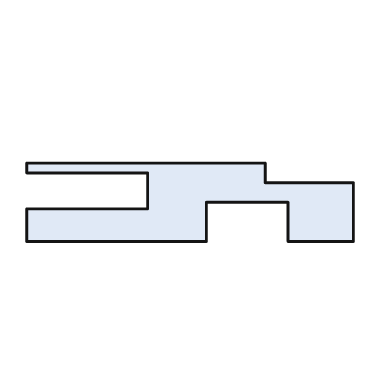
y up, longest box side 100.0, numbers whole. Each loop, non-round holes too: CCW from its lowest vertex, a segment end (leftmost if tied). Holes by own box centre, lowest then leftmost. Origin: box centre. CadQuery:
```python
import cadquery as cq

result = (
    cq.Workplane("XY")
    .moveTo(-50.0, -12.0)
    .lineTo(5.0, -12.0)
    .lineTo(5.0, 0.0)
    .lineTo(30.0, 0.0)
    .lineTo(30.0, -12.0)
    .lineTo(50.0, -12.0)
    .lineTo(50.0, 6.0)
    .lineTo(23.0, 6.0)
    .lineTo(23.0, 12.0)
    .lineTo(-50.0, 12.0)
    .lineTo(-50.0, 9.0)
    .lineTo(-13.0, 9.0)
    .lineTo(-13.0, -2.0)
    .lineTo(-50.0, -2.0)
    .close()
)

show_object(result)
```